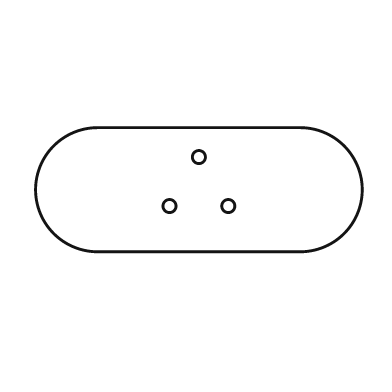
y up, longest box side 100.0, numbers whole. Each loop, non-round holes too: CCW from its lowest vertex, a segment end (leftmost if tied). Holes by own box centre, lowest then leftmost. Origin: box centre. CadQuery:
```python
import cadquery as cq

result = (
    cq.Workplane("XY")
    .moveTo(-31.0, -19.0)
    .lineTo(31.0, -19.0)
    .threePointArc((50.0, 0.0), (31.0, 19.0))
    .lineTo(-31.0, 19.0)
    .threePointArc((-50.0, 0.0), (-31.0, -19.0))
    .close()
    .moveTo(-9.0, -5.0)
    .circle(2.0)
    .moveTo(9.0, -5.0)
    .circle(2.0)
    .moveTo(0.0, 10.0)
    .circle(2.0)
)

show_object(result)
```